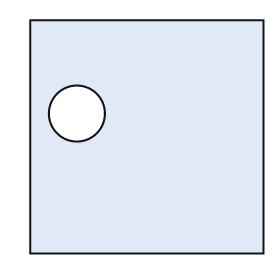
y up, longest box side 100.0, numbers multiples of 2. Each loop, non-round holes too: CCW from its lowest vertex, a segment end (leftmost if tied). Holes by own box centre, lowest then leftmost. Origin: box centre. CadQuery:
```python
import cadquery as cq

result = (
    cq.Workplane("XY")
    .moveTo(-50.0, -50.0)
    .lineTo(50.0, -50.0)
    .lineTo(50.0, 50.0)
    .lineTo(-50.0, 50.0)
    .close()
    .moveTo(-30.0, 10.0)
    .circle(12.0)
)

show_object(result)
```